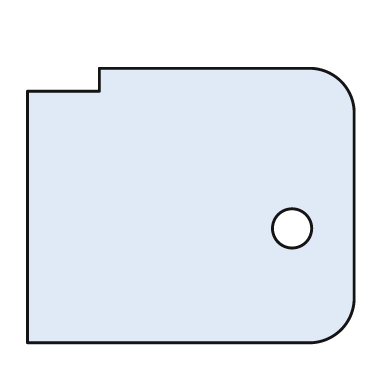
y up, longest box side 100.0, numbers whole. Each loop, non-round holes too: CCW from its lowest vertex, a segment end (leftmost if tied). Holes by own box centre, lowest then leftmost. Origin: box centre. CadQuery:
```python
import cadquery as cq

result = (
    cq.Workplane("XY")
    .moveTo(-50.0, -42.0)
    .lineTo(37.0, -42.0)
    .threePointArc((46.0, -38.0), (50.0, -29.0))
    .lineTo(50.0, 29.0)
    .threePointArc((46.0, 38.0), (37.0, 42.0))
    .lineTo(-28.0, 42.0)
    .lineTo(-28.0, 35.0)
    .lineTo(-50.0, 35.0)
    .close()
    .moveTo(31.0, -7.0)
    .circle(6.0)
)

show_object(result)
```